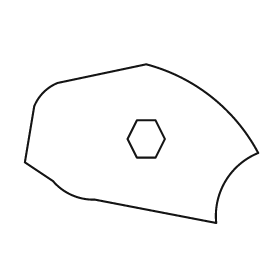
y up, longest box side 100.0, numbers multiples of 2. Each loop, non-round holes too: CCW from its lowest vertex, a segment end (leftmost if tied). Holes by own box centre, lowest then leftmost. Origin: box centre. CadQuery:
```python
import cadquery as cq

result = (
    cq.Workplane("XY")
    .moveTo(32.0, -34.0)
    .threePointArc((36.0, -16.0), (50.0, -4.0))
    .threePointArc((30.0, 20.0), (2.0, 34.0))
    .lineTo(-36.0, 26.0)
    .threePointArc((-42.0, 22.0), (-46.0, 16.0))
    .lineTo(-50.0, -8.0)
    .lineTo(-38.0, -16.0)
    .threePointArc((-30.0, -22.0), (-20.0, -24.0))
    .close()
    .moveTo(-2.0, -6.0)
    .lineTo(6.0, -6.0)
    .lineTo(10.0, 2.0)
    .lineTo(6.0, 10.0)
    .lineTo(-2.0, 10.0)
    .lineTo(-6.0, 2.0)
    .close()
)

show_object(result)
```